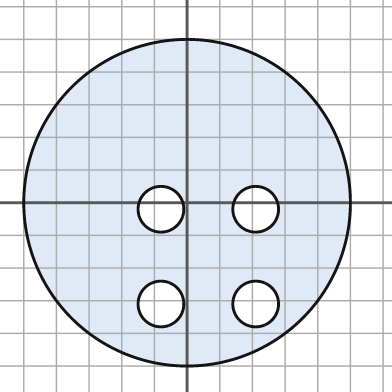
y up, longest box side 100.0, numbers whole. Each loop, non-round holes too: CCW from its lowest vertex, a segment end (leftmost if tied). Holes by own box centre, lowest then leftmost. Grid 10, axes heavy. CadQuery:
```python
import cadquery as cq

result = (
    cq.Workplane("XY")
    .moveTo(0.0, 0.0)
    .circle(50.0)
    .moveTo(-8.0, -31.0)
    .circle(7.0)
    .moveTo(21.0, -31.0)
    .circle(7.0)
    .moveTo(-8.0, -2.0)
    .circle(7.0)
    .moveTo(21.0, -2.0)
    .circle(7.0)
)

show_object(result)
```